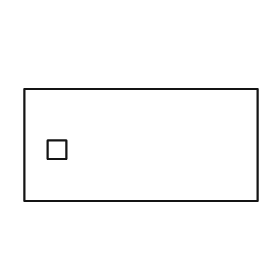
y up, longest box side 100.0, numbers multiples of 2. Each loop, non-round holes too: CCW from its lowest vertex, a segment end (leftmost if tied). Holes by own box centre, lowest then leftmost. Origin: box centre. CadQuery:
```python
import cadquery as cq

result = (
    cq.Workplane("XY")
    .moveTo(-50.0, -24.0)
    .lineTo(50.0, -24.0)
    .lineTo(50.0, 24.0)
    .lineTo(-50.0, 24.0)
    .close()
    .moveTo(-40.0, -6.0)
    .lineTo(-32.0, -6.0)
    .lineTo(-32.0, 2.0)
    .lineTo(-40.0, 2.0)
    .close()
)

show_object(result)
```